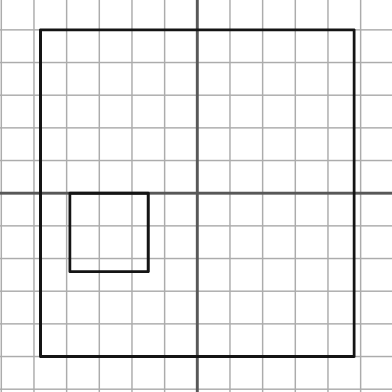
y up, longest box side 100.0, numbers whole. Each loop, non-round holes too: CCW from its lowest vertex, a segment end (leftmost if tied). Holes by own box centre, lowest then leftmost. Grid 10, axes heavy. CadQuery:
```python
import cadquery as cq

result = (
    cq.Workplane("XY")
    .moveTo(-48.0, -50.0)
    .lineTo(48.0, -50.0)
    .lineTo(48.0, 50.0)
    .lineTo(-48.0, 50.0)
    .close()
    .moveTo(-39.0, -24.0)
    .lineTo(-15.0, -24.0)
    .lineTo(-15.0, 0.0)
    .lineTo(-39.0, 0.0)
    .close()
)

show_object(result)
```